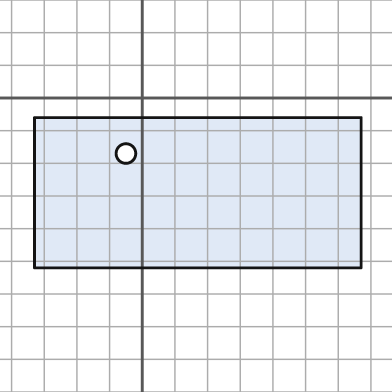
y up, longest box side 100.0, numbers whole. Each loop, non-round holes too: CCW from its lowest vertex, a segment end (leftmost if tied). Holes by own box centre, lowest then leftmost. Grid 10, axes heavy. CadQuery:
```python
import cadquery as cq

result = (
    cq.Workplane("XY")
    .moveTo(-33.0, -52.0)
    .lineTo(67.0, -52.0)
    .lineTo(67.0, -6.0)
    .lineTo(-33.0, -6.0)
    .close()
    .moveTo(-5.0, -17.0)
    .circle(3.0)
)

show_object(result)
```